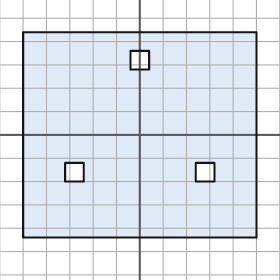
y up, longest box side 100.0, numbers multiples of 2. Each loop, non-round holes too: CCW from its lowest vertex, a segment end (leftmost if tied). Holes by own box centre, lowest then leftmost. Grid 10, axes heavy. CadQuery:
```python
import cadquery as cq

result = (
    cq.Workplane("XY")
    .moveTo(-50.0, -44.0)
    .lineTo(50.0, -44.0)
    .lineTo(50.0, 44.0)
    .lineTo(-50.0, 44.0)
    .close()
    .moveTo(-32.0, -20.0)
    .lineTo(-24.0, -20.0)
    .lineTo(-24.0, -12.0)
    .lineTo(-32.0, -12.0)
    .close()
    .moveTo(24.0, -20.0)
    .lineTo(32.0, -20.0)
    .lineTo(32.0, -12.0)
    .lineTo(24.0, -12.0)
    .close()
    .moveTo(-4.0, 28.0)
    .lineTo(4.0, 28.0)
    .lineTo(4.0, 36.0)
    .lineTo(-4.0, 36.0)
    .close()
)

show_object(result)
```